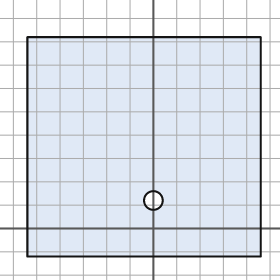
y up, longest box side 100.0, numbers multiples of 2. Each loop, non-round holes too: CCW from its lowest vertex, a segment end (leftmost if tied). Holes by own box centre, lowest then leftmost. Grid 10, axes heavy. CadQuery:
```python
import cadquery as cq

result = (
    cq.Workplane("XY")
    .moveTo(-54.0, -12.0)
    .lineTo(46.0, -12.0)
    .lineTo(46.0, 82.0)
    .lineTo(-54.0, 82.0)
    .close()
    .moveTo(0.0, 12.0)
    .circle(4.0)
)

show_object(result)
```